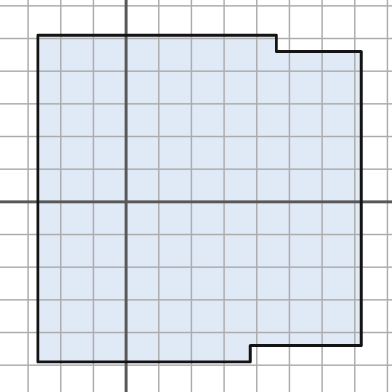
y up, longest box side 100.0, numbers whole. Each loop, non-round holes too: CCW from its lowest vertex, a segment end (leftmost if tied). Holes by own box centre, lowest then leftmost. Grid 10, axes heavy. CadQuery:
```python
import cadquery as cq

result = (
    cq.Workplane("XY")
    .moveTo(-27.0, -49.0)
    .lineTo(38.0, -49.0)
    .lineTo(38.0, -44.0)
    .lineTo(72.0, -44.0)
    .lineTo(72.0, 46.0)
    .lineTo(46.0, 46.0)
    .lineTo(46.0, 51.0)
    .lineTo(-27.0, 51.0)
    .close()
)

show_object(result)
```